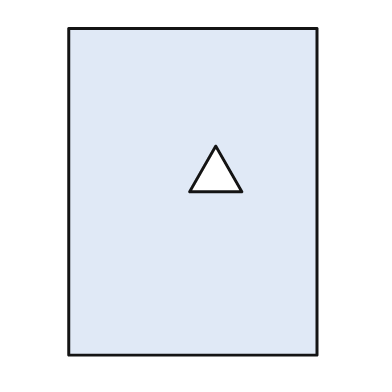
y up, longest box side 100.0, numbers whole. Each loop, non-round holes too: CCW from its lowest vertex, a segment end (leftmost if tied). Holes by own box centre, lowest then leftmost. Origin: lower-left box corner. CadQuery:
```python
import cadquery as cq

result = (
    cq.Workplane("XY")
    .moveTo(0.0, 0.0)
    .lineTo(76.0, 0.0)
    .lineTo(76.0, 100.0)
    .lineTo(0.0, 100.0)
    .close()
    .moveTo(37.0, 50.0)
    .lineTo(53.0, 50.0)
    .lineTo(45.0, 64.0)
    .close()
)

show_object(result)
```